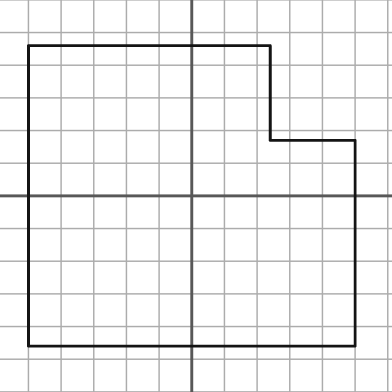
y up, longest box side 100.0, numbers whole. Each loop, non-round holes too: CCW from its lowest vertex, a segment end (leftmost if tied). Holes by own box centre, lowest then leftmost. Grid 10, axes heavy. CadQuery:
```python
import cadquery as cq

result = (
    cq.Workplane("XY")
    .moveTo(-50.0, -46.0)
    .lineTo(50.0, -46.0)
    .lineTo(50.0, 17.0)
    .lineTo(24.0, 17.0)
    .lineTo(24.0, 46.0)
    .lineTo(-50.0, 46.0)
    .close()
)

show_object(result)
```